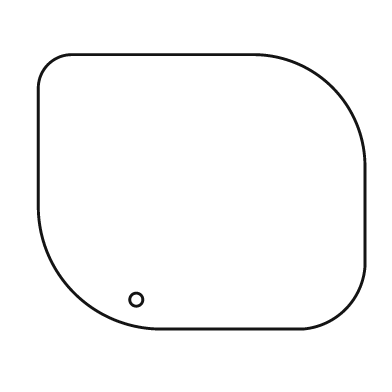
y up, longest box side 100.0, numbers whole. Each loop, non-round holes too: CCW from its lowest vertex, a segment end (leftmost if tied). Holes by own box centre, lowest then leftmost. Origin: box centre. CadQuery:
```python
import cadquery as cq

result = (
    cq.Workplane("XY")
    .moveTo(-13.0, -42.0)
    .lineTo(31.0, -42.0)
    .threePointArc((44.0, -36.0), (50.0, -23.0))
    .lineTo(50.0, 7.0)
    .threePointArc((40.0, 32.0), (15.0, 42.0))
    .lineTo(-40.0, 42.0)
    .threePointArc((-47.0, 39.0), (-50.0, 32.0))
    .lineTo(-50.0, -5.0)
    .threePointArc((-39.0, -31.0), (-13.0, -42.0))
    .close()
    .moveTo(-20.0, -33.0)
    .circle(2.0)
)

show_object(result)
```